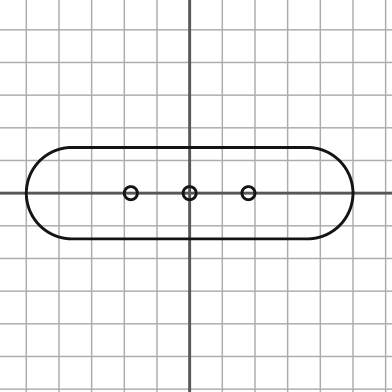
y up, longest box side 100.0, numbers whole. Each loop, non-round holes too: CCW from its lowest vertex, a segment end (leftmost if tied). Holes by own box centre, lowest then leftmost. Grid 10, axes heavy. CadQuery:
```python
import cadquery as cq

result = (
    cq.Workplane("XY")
    .moveTo(-36.0, -14.0)
    .lineTo(36.0, -14.0)
    .threePointArc((50.0, 0.0), (36.0, 14.0))
    .lineTo(-36.0, 14.0)
    .threePointArc((-50.0, 0.0), (-36.0, -14.0))
    .close()
    .moveTo(-18.0, 0.0)
    .circle(2.0)
    .moveTo(0.0, 0.0)
    .circle(2.0)
    .moveTo(18.0, 0.0)
    .circle(2.0)
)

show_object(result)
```